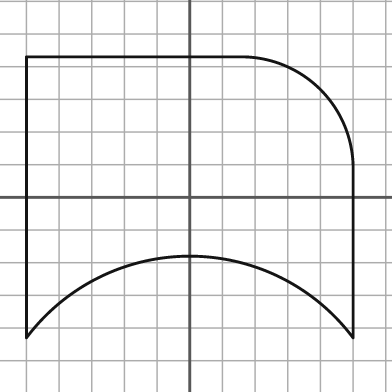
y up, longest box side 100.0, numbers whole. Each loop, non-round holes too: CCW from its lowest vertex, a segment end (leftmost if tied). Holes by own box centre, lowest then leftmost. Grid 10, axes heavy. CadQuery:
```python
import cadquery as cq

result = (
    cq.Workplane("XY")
    .moveTo(-50.0, -43.0)
    .threePointArc((0.0, -18.0), (50.0, -43.0))
    .lineTo(50.0, 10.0)
    .threePointArc((40.0, 33.0), (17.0, 43.0))
    .lineTo(-50.0, 43.0)
    .close()
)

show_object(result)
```